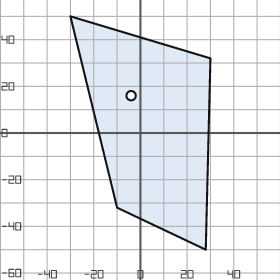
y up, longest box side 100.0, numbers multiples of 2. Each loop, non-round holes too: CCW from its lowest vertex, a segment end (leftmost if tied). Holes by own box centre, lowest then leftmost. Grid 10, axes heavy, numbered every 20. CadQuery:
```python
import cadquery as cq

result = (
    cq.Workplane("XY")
    .moveTo(28.0, -50.0)
    .lineTo(30.0, 32.0)
    .lineTo(-30.0, 50.0)
    .lineTo(-10.0, -32.0)
    .close()
    .moveTo(-4.0, 16.0)
    .circle(2.0)
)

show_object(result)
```